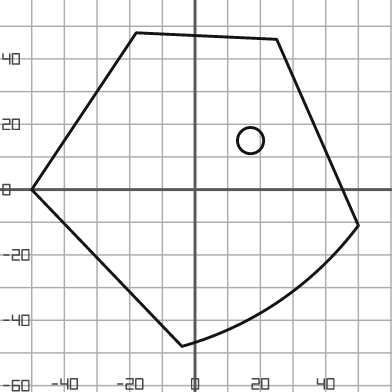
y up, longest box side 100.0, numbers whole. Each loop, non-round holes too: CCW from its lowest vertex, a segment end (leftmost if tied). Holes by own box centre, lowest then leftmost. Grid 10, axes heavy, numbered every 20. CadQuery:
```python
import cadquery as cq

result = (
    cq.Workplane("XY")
    .moveTo(-4.0, -48.0)
    .threePointArc((26.0, -34.0), (50.0, -11.0))
    .lineTo(25.0, 46.0)
    .lineTo(-18.0, 48.0)
    .lineTo(-50.0, 0.0)
    .close()
    .moveTo(17.0, 15.0)
    .circle(4.0)
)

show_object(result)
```